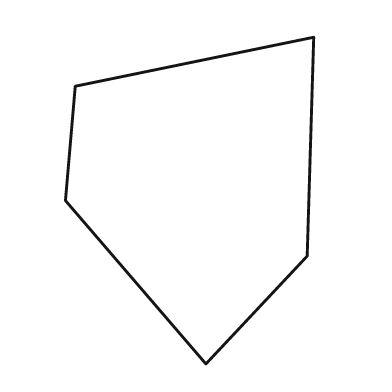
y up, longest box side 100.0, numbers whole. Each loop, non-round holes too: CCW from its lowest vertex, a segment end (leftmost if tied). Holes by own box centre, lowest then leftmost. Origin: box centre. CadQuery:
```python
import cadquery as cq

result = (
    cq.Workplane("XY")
    .moveTo(5.0, -50.0)
    .lineTo(36.0, -17.0)
    .lineTo(38.0, 50.0)
    .lineTo(-35.0, 35.0)
    .lineTo(-38.0, 0.0)
    .close()
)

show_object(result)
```